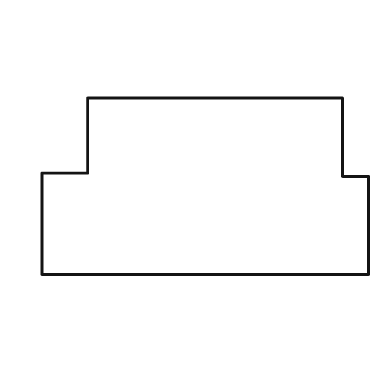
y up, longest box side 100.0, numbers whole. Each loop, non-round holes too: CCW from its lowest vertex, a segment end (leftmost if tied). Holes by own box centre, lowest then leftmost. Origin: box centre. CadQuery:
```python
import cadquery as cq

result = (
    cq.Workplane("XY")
    .moveTo(-50.0, -27.0)
    .lineTo(50.0, -27.0)
    .lineTo(50.0, 3.0)
    .lineTo(42.0, 3.0)
    .lineTo(42.0, 27.0)
    .lineTo(-36.0, 27.0)
    .lineTo(-36.0, 4.0)
    .lineTo(-50.0, 4.0)
    .close()
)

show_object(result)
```